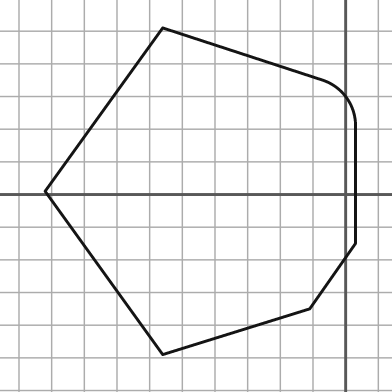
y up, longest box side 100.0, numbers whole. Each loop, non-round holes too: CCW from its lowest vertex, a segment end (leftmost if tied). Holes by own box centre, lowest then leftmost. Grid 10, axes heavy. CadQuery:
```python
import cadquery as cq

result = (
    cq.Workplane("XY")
    .moveTo(-56.0, -49.0)
    .lineTo(-11.0, -35.0)
    .lineTo(3.0, -15.0)
    .lineTo(3.0, 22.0)
    .threePointArc((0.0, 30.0), (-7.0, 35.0))
    .lineTo(-56.0, 51.0)
    .lineTo(-92.0, 1.0)
    .close()
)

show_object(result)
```